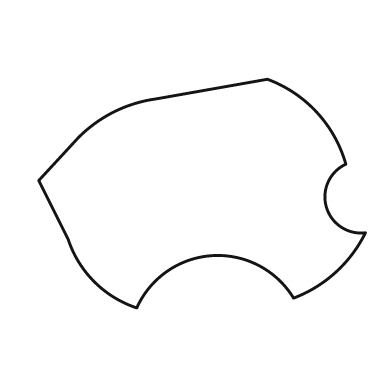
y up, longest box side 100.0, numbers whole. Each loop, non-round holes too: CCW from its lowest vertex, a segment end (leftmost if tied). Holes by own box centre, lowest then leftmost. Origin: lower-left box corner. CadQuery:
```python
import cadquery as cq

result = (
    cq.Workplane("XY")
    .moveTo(30.0, 0.0)
    .threePointArc((53.0, 16.0), (78.0, 3.0))
    .threePointArc((91.0, 11.0), (100.0, 23.0))
    .threePointArc((88.0, 31.0), (94.0, 44.0))
    .threePointArc((85.0, 60.0), (70.0, 70.0))
    .lineTo(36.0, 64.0)
    .threePointArc((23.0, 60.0), (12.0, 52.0))
    .lineTo(0.0, 39.0)
    .lineTo(9.0, 21.0)
    .threePointArc((17.0, 8.0), (30.0, 0.0))
    .close()
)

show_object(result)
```